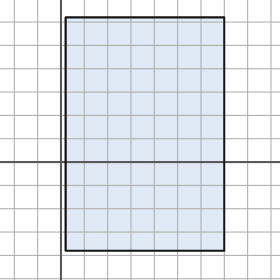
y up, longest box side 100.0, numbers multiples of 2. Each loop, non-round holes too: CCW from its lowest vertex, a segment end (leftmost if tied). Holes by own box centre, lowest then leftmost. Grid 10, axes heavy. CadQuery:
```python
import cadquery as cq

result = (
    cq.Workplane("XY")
    .moveTo(2.0, -38.0)
    .lineTo(70.0, -38.0)
    .lineTo(70.0, 62.0)
    .lineTo(2.0, 62.0)
    .close()
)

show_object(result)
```